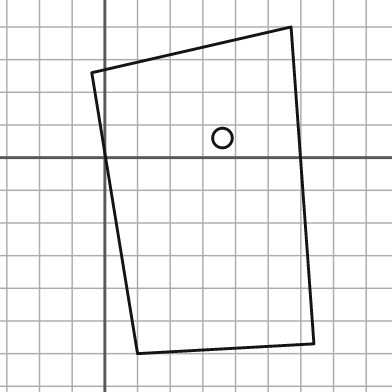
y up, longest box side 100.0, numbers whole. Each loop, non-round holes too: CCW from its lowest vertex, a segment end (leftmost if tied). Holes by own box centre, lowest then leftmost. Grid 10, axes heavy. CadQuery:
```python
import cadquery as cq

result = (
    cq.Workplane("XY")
    .moveTo(10.0, -60.0)
    .lineTo(64.0, -57.0)
    .lineTo(57.0, 40.0)
    .lineTo(-4.0, 26.0)
    .close()
    .moveTo(36.0, 6.0)
    .circle(3.0)
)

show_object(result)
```